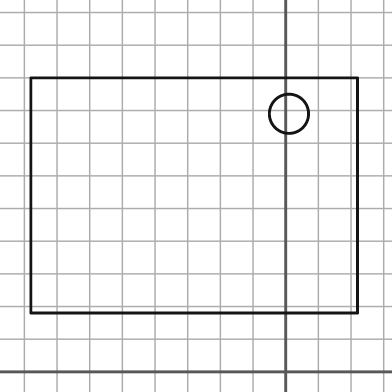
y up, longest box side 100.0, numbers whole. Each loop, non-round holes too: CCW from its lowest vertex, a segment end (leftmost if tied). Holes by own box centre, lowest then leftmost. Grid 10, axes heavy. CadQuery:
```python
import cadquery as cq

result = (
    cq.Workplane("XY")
    .moveTo(-78.0, 18.0)
    .lineTo(22.0, 18.0)
    .lineTo(22.0, 90.0)
    .lineTo(-78.0, 90.0)
    .close()
    .moveTo(1.0, 79.0)
    .circle(6.0)
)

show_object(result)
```